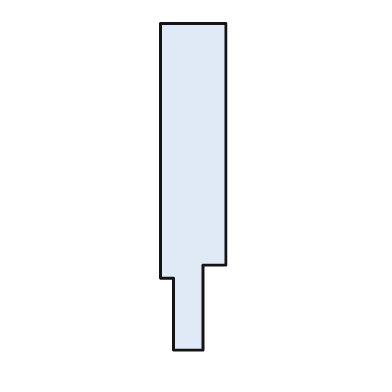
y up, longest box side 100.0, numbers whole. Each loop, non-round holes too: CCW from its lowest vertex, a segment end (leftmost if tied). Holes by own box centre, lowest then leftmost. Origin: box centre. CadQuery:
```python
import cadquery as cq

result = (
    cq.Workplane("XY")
    .moveTo(-6.0, -50.0)
    .lineTo(3.0, -50.0)
    .lineTo(3.0, -24.0)
    .lineTo(10.0, -24.0)
    .lineTo(10.0, 50.0)
    .lineTo(-10.0, 50.0)
    .lineTo(-10.0, -28.0)
    .lineTo(-6.0, -28.0)
    .close()
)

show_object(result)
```